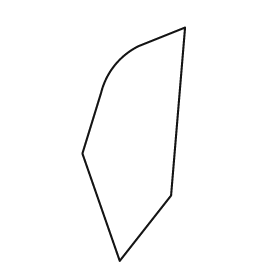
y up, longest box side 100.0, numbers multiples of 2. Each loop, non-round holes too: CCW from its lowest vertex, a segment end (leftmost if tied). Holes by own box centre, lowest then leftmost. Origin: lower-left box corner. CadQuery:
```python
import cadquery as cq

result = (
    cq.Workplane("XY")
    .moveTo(16.0, 0.0)
    .lineTo(38.0, 28.0)
    .lineTo(44.0, 100.0)
    .lineTo(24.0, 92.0)
    .threePointArc((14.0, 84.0), (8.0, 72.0))
    .lineTo(0.0, 46.0)
    .close()
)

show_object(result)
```